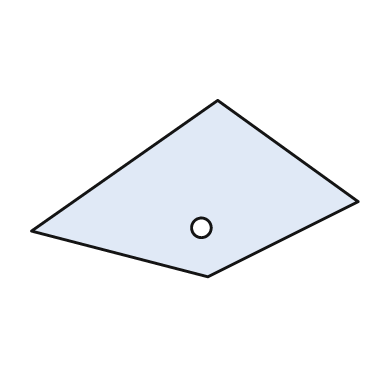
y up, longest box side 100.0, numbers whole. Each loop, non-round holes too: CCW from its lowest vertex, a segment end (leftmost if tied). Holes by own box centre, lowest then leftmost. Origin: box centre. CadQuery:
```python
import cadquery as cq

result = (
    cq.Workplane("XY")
    .moveTo(4.0, -27.0)
    .lineTo(50.0, -4.0)
    .lineTo(7.0, 27.0)
    .lineTo(-50.0, -13.0)
    .close()
    .moveTo(2.0, -12.0)
    .circle(3.0)
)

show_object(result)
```